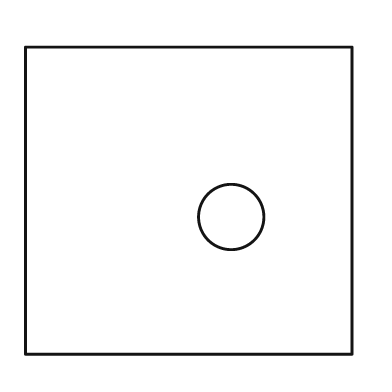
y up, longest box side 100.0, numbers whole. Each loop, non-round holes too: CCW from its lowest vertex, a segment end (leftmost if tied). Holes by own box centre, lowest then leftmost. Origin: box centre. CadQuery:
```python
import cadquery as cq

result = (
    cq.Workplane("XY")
    .moveTo(-50.0, -47.0)
    .lineTo(50.0, -47.0)
    .lineTo(50.0, 47.0)
    .lineTo(-50.0, 47.0)
    .close()
    .moveTo(13.0, -5.0)
    .circle(10.0)
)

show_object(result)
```